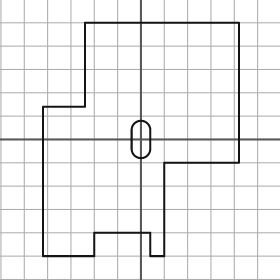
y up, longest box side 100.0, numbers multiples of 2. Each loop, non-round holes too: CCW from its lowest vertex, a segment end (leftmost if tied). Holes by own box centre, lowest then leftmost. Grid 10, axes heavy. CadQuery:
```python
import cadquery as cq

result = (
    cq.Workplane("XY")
    .moveTo(-42.0, -50.0)
    .lineTo(-20.0, -50.0)
    .lineTo(-20.0, -40.0)
    .lineTo(4.0, -40.0)
    .lineTo(4.0, -50.0)
    .lineTo(10.0, -50.0)
    .lineTo(10.0, -10.0)
    .lineTo(42.0, -10.0)
    .lineTo(42.0, 50.0)
    .lineTo(-24.0, 50.0)
    .lineTo(-24.0, 14.0)
    .lineTo(-42.0, 14.0)
    .close()
    .moveTo(-4.0, -4.0)
    .threePointArc((0.0, -8.0), (4.0, -4.0))
    .lineTo(4.0, 4.0)
    .threePointArc((0.0, 8.0), (-4.0, 4.0))
    .close()
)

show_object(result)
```